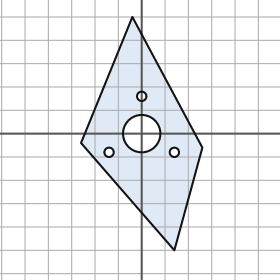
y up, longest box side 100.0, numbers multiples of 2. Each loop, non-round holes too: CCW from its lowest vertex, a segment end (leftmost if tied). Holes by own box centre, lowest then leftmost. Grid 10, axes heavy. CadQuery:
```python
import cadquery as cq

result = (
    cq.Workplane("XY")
    .moveTo(14.0, -50.0)
    .lineTo(26.0, -6.0)
    .lineTo(-4.0, 50.0)
    .lineTo(-26.0, -4.0)
    .close()
    .moveTo(-14.0, -8.0)
    .circle(2.0)
    .moveTo(14.0, -8.0)
    .circle(2.0)
    .moveTo(0.0, 0.0)
    .circle(8.0)
    .moveTo(0.0, 16.0)
    .circle(2.0)
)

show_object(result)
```